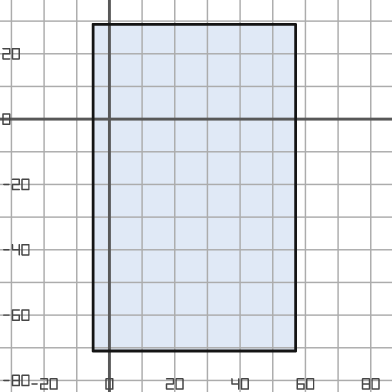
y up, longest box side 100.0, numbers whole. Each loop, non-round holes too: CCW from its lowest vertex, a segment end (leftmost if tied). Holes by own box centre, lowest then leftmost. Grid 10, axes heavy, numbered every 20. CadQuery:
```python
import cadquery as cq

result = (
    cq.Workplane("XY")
    .moveTo(-5.0, -71.0)
    .lineTo(57.0, -71.0)
    .lineTo(57.0, 29.0)
    .lineTo(-5.0, 29.0)
    .close()
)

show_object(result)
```